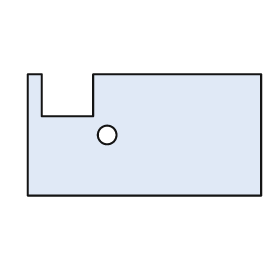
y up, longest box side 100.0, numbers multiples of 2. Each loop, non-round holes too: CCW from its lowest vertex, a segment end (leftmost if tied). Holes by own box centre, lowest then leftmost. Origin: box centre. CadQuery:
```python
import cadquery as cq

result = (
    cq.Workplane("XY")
    .moveTo(-50.0, -26.0)
    .lineTo(50.0, -26.0)
    .lineTo(50.0, 26.0)
    .lineTo(-22.0, 26.0)
    .lineTo(-22.0, 8.0)
    .lineTo(-44.0, 8.0)
    .lineTo(-44.0, 26.0)
    .lineTo(-50.0, 26.0)
    .close()
    .moveTo(-16.0, 0.0)
    .circle(4.0)
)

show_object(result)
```